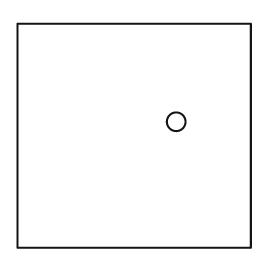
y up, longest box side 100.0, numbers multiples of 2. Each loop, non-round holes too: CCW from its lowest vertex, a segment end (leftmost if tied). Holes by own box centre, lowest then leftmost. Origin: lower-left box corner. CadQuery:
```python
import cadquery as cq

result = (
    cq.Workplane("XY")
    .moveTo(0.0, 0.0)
    .lineTo(100.0, 0.0)
    .lineTo(100.0, 96.0)
    .lineTo(0.0, 96.0)
    .close()
    .moveTo(68.0, 54.0)
    .circle(4.0)
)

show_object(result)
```